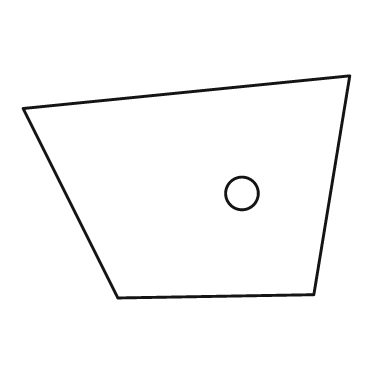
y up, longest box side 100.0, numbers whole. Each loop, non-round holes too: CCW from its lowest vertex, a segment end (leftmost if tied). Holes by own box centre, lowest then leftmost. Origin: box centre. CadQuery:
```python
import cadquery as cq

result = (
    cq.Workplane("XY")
    .moveTo(-21.0, -34.0)
    .lineTo(39.0, -33.0)
    .lineTo(50.0, 34.0)
    .lineTo(-50.0, 24.0)
    .close()
    .moveTo(17.0, -2.0)
    .circle(5.0)
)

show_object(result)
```